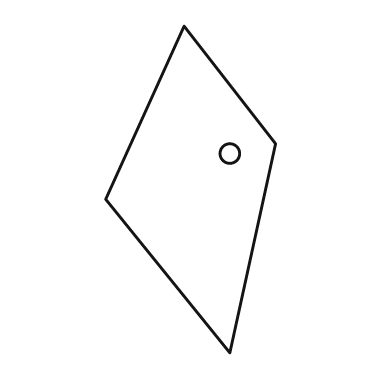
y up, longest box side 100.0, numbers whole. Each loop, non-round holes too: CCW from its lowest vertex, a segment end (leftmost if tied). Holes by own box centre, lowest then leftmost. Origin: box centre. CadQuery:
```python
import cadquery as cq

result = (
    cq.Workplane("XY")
    .moveTo(12.0, -50.0)
    .lineTo(26.0, 14.0)
    .lineTo(-2.0, 50.0)
    .lineTo(-26.0, -3.0)
    .close()
    .moveTo(12.0, 11.0)
    .circle(3.0)
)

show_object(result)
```